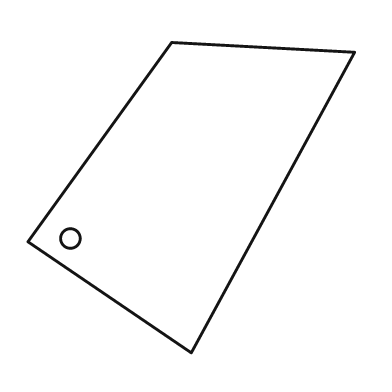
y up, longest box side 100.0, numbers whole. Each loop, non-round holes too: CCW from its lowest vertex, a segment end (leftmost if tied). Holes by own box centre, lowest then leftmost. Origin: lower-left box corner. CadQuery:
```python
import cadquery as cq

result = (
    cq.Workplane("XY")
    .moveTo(50.0, 0.0)
    .lineTo(100.0, 92.0)
    .lineTo(44.0, 95.0)
    .lineTo(0.0, 34.0)
    .close()
    .moveTo(13.0, 35.0)
    .circle(3.0)
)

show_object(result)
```